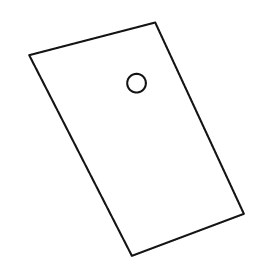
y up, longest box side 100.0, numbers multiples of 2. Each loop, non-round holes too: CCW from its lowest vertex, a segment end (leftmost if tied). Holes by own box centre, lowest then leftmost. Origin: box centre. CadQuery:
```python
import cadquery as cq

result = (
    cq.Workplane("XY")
    .moveTo(-2.0, -50.0)
    .lineTo(46.0, -32.0)
    .lineTo(8.0, 50.0)
    .lineTo(-46.0, 36.0)
    .close()
    .moveTo(0.0, 24.0)
    .circle(4.0)
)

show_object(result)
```